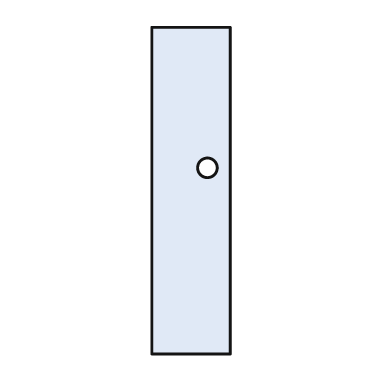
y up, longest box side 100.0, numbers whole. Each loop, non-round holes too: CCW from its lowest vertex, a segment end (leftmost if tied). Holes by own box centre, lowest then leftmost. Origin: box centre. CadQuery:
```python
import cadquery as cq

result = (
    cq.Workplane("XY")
    .moveTo(-12.0, -50.0)
    .lineTo(12.0, -50.0)
    .lineTo(12.0, 50.0)
    .lineTo(-12.0, 50.0)
    .close()
    .moveTo(5.0, 7.0)
    .circle(3.0)
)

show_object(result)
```